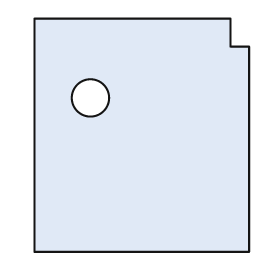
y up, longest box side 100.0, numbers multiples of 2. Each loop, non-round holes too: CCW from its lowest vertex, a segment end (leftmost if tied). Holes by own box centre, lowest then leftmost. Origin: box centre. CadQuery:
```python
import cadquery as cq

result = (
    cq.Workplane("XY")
    .moveTo(-46.0, -50.0)
    .lineTo(46.0, -50.0)
    .lineTo(46.0, 38.0)
    .lineTo(38.0, 38.0)
    .lineTo(38.0, 50.0)
    .lineTo(-46.0, 50.0)
    .close()
    .moveTo(-22.0, 16.0)
    .circle(8.0)
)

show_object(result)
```